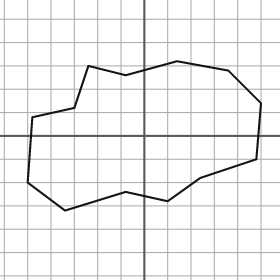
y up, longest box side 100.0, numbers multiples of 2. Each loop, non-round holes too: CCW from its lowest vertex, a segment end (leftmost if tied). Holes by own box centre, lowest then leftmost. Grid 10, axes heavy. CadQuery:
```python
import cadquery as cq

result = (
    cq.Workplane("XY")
    .moveTo(-34.0, -32.0)
    .lineTo(-8.0, -24.0)
    .lineTo(10.0, -28.0)
    .lineTo(24.0, -18.0)
    .lineTo(48.0, -10.0)
    .lineTo(50.0, 14.0)
    .lineTo(36.0, 28.0)
    .lineTo(14.0, 32.0)
    .lineTo(-8.0, 26.0)
    .lineTo(-24.0, 30.0)
    .lineTo(-30.0, 12.0)
    .lineTo(-48.0, 8.0)
    .lineTo(-50.0, -20.0)
    .close()
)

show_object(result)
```